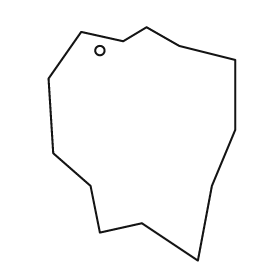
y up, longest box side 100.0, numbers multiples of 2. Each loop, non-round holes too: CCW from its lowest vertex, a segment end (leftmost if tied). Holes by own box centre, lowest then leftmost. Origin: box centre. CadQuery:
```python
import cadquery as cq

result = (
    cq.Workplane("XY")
    .moveTo(24.0, -50.0)
    .lineTo(30.0, -18.0)
    .lineTo(40.0, 6.0)
    .lineTo(40.0, 36.0)
    .lineTo(16.0, 42.0)
    .lineTo(2.0, 50.0)
    .lineTo(-8.0, 44.0)
    .lineTo(-26.0, 48.0)
    .lineTo(-40.0, 28.0)
    .lineTo(-38.0, -4.0)
    .lineTo(-22.0, -18.0)
    .lineTo(-18.0, -38.0)
    .lineTo(0.0, -34.0)
    .close()
    .moveTo(-18.0, 40.0)
    .circle(2.0)
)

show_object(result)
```